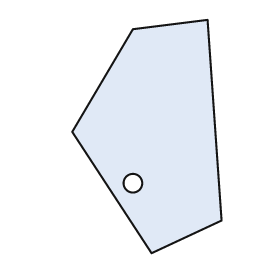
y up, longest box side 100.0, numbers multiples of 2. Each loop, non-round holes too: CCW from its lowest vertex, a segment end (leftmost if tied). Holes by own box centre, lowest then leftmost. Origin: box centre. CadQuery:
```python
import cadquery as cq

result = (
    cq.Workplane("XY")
    .moveTo(2.0, -50.0)
    .lineTo(32.0, -36.0)
    .lineTo(26.0, 50.0)
    .lineTo(-6.0, 46.0)
    .lineTo(-32.0, 2.0)
    .close()
    .moveTo(-6.0, -20.0)
    .circle(4.0)
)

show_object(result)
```